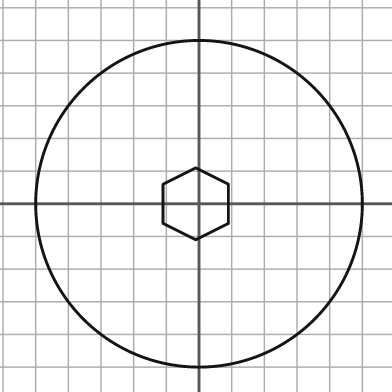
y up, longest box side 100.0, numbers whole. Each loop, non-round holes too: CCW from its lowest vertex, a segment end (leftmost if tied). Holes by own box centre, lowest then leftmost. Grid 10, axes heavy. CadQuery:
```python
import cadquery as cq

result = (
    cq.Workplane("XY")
    .moveTo(0.0, 0.0)
    .circle(50.0)
    .moveTo(-1.0, -11.0)
    .lineTo(9.0, -6.0)
    .lineTo(9.0, 6.0)
    .lineTo(-1.0, 11.0)
    .lineTo(-11.0, 6.0)
    .lineTo(-11.0, -6.0)
    .close()
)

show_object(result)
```